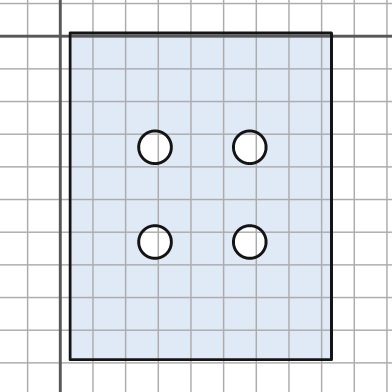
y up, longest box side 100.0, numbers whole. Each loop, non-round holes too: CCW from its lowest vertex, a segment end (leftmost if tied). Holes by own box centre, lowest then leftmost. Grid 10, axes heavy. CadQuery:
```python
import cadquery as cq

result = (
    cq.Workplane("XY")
    .moveTo(3.0, -99.0)
    .lineTo(83.0, -99.0)
    .lineTo(83.0, 1.0)
    .lineTo(3.0, 1.0)
    .close()
    .moveTo(29.0, -63.0)
    .circle(5.0)
    .moveTo(58.0, -63.0)
    .circle(5.0)
    .moveTo(29.0, -34.0)
    .circle(5.0)
    .moveTo(58.0, -34.0)
    .circle(5.0)
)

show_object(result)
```